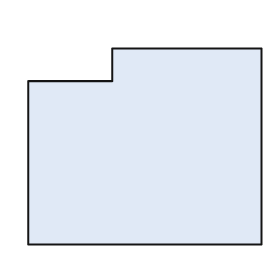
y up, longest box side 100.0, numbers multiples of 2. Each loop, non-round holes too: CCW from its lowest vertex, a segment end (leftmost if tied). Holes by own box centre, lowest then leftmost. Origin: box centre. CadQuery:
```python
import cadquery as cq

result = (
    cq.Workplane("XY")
    .moveTo(-50.0, -42.0)
    .lineTo(50.0, -42.0)
    .lineTo(50.0, 42.0)
    .lineTo(-14.0, 42.0)
    .lineTo(-14.0, 28.0)
    .lineTo(-50.0, 28.0)
    .close()
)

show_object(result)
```